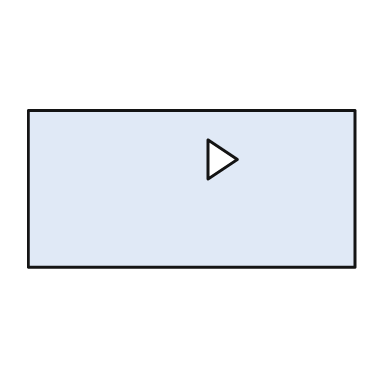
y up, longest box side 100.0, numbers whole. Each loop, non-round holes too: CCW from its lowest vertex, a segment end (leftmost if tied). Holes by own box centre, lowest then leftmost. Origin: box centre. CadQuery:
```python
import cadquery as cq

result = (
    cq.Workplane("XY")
    .moveTo(-50.0, -24.0)
    .lineTo(50.0, -24.0)
    .lineTo(50.0, 24.0)
    .lineTo(-50.0, 24.0)
    .close()
    .moveTo(5.0, 3.0)
    .lineTo(14.0, 9.0)
    .lineTo(5.0, 15.0)
    .close()
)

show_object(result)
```